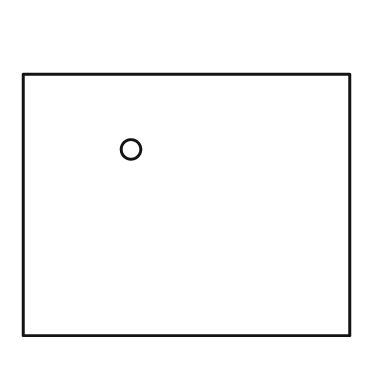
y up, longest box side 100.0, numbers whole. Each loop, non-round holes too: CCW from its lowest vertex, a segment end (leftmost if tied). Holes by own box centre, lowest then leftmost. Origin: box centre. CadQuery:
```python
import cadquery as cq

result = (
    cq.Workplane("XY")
    .moveTo(-50.0, -40.0)
    .lineTo(50.0, -40.0)
    .lineTo(50.0, 40.0)
    .lineTo(-50.0, 40.0)
    .close()
    .moveTo(-17.0, 17.0)
    .circle(3.0)
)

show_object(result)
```